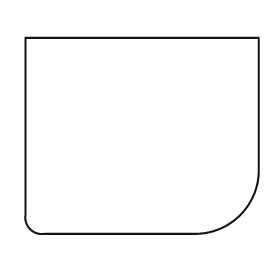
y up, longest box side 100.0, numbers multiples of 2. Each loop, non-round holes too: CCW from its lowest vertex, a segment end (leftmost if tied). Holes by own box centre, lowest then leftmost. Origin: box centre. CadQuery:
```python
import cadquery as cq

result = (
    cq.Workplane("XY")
    .moveTo(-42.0, -42.0)
    .lineTo(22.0, -42.0)
    .threePointArc((42.0, -34.0), (50.0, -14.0))
    .lineTo(50.0, 42.0)
    .lineTo(-50.0, 42.0)
    .lineTo(-50.0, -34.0)
    .threePointArc((-48.0, -40.0), (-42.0, -42.0))
    .close()
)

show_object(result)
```